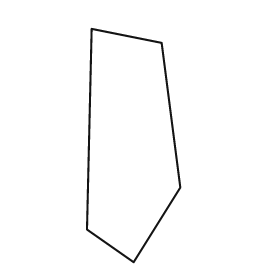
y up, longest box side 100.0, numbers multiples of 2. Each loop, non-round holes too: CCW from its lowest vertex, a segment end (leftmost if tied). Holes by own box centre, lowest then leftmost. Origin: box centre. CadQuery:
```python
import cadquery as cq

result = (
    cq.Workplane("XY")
    .moveTo(0.0, -50.0)
    .lineTo(20.0, -18.0)
    .lineTo(12.0, 44.0)
    .lineTo(-18.0, 50.0)
    .lineTo(-20.0, -36.0)
    .close()
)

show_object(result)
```